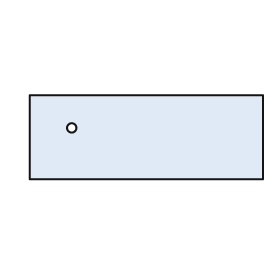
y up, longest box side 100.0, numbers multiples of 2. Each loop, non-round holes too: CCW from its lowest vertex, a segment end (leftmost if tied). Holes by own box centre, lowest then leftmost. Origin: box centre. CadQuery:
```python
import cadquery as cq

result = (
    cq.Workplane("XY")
    .moveTo(-50.0, -18.0)
    .lineTo(50.0, -18.0)
    .lineTo(50.0, 18.0)
    .lineTo(-50.0, 18.0)
    .close()
    .moveTo(-32.0, 4.0)
    .circle(2.0)
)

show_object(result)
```